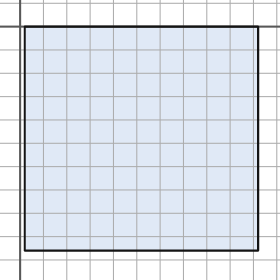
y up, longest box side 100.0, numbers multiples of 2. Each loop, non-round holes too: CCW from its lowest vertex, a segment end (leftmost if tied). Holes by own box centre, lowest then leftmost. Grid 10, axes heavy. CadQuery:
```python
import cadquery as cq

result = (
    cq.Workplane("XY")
    .moveTo(2.0, -96.0)
    .lineTo(102.0, -96.0)
    .lineTo(102.0, 0.0)
    .lineTo(2.0, 0.0)
    .close()
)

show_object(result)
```